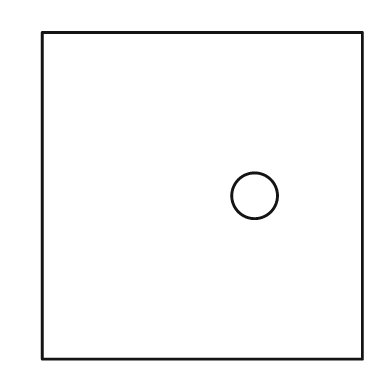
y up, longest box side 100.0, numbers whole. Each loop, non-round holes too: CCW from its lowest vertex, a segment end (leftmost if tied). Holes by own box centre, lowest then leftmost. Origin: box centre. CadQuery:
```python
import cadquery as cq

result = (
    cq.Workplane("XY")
    .moveTo(-49.0, -50.0)
    .lineTo(49.0, -50.0)
    .lineTo(49.0, 50.0)
    .lineTo(-49.0, 50.0)
    .close()
    .moveTo(16.0, 0.0)
    .circle(7.0)
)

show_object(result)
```